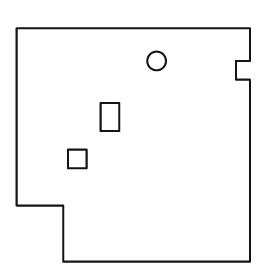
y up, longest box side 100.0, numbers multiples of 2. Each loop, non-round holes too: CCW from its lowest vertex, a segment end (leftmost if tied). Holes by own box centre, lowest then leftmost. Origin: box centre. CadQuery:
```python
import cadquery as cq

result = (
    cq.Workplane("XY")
    .moveTo(-30.0, -50.0)
    .lineTo(50.0, -50.0)
    .lineTo(50.0, 28.0)
    .lineTo(44.0, 28.0)
    .lineTo(44.0, 36.0)
    .lineTo(50.0, 36.0)
    .lineTo(50.0, 50.0)
    .lineTo(-50.0, 50.0)
    .lineTo(-50.0, -26.0)
    .lineTo(-30.0, -26.0)
    .close()
    .moveTo(-28.0, -10.0)
    .lineTo(-20.0, -10.0)
    .lineTo(-20.0, -2.0)
    .lineTo(-28.0, -2.0)
    .close()
    .moveTo(-14.0, 6.0)
    .lineTo(-6.0, 6.0)
    .lineTo(-6.0, 18.0)
    .lineTo(-14.0, 18.0)
    .close()
    .moveTo(10.0, 36.0)
    .circle(4.0)
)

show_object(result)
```